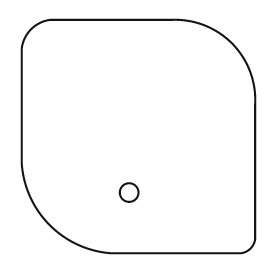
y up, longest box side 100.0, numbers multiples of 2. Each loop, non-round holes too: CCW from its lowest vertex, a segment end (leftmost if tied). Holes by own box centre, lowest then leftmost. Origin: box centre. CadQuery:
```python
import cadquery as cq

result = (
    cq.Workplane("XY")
    .moveTo(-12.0, -50.0)
    .lineTo(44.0, -50.0)
    .threePointArc((48.0, -48.0), (50.0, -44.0))
    .lineTo(50.0, 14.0)
    .threePointArc((40.0, 40.0), (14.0, 50.0))
    .lineTo(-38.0, 50.0)
    .threePointArc((-46.0, 46.0), (-50.0, 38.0))
    .lineTo(-50.0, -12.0)
    .threePointArc((-38.0, -38.0), (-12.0, -50.0))
    .close()
    .moveTo(-4.0, -24.0)
    .circle(4.0)
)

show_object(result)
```